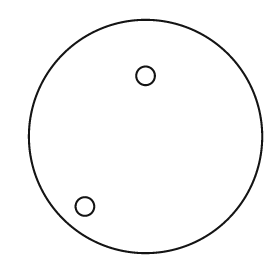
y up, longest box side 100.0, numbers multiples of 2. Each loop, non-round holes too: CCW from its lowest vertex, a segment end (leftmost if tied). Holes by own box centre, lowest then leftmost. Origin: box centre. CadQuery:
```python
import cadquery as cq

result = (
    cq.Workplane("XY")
    .moveTo(0.0, 0.0)
    .circle(50.0)
    .moveTo(-26.0, -30.0)
    .circle(4.0)
    .moveTo(0.0, 26.0)
    .circle(4.0)
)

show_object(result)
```